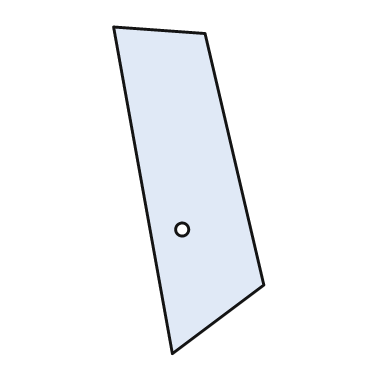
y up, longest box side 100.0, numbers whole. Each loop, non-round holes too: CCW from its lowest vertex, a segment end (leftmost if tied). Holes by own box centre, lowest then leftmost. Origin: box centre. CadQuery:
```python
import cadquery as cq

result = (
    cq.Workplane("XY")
    .moveTo(-5.0, -50.0)
    .lineTo(23.0, -29.0)
    .lineTo(5.0, 48.0)
    .lineTo(-23.0, 50.0)
    .close()
    .moveTo(-2.0, -12.0)
    .circle(2.0)
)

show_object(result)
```